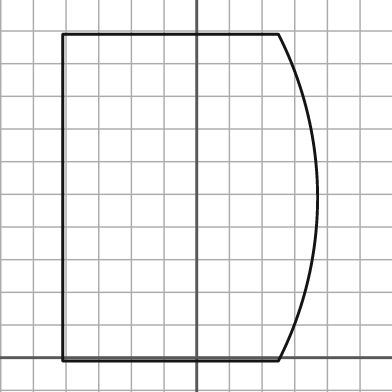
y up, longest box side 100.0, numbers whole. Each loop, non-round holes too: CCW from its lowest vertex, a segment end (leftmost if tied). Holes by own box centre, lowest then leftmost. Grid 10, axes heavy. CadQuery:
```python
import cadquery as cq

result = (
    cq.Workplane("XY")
    .moveTo(-41.0, -1.0)
    .lineTo(25.0, -1.0)
    .threePointArc((37.0, 49.0), (25.0, 99.0))
    .lineTo(-41.0, 99.0)
    .close()
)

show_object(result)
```